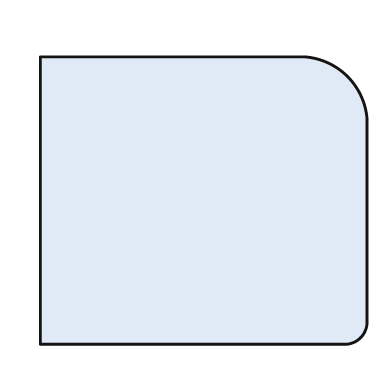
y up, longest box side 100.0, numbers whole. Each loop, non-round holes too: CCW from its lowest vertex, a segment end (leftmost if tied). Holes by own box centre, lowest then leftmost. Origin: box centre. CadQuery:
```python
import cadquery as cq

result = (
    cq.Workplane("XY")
    .moveTo(-50.0, -44.0)
    .lineTo(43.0, -44.0)
    .threePointArc((48.0, -42.0), (50.0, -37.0))
    .lineTo(50.0, 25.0)
    .threePointArc((44.0, 38.0), (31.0, 44.0))
    .lineTo(-50.0, 44.0)
    .close()
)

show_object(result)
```